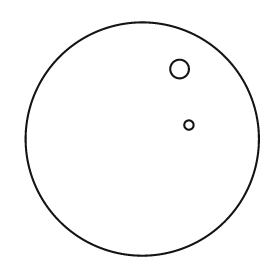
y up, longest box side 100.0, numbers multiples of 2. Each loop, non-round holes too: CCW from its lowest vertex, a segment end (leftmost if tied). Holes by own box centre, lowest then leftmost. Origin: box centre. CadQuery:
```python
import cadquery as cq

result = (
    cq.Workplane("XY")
    .moveTo(0.0, 0.0)
    .circle(50.0)
    .moveTo(20.0, 6.0)
    .circle(2.0)
    .moveTo(16.0, 30.0)
    .circle(4.0)
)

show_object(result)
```